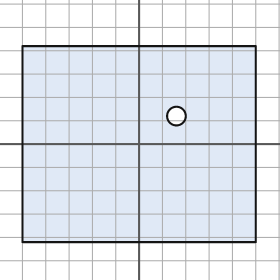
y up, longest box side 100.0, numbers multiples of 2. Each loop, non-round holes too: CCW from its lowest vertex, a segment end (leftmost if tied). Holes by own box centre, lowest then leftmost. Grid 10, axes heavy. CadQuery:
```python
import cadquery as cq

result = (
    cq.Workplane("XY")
    .moveTo(-50.0, -42.0)
    .lineTo(50.0, -42.0)
    .lineTo(50.0, 42.0)
    .lineTo(-50.0, 42.0)
    .close()
    .moveTo(16.0, 12.0)
    .circle(4.0)
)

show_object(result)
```